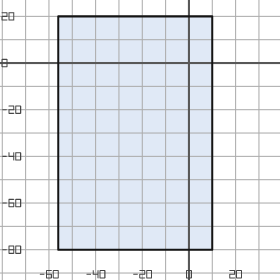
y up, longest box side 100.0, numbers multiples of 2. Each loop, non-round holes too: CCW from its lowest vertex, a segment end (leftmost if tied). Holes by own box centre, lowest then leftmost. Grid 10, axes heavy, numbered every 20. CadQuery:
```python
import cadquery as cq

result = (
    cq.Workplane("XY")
    .moveTo(-56.0, -80.0)
    .lineTo(10.0, -80.0)
    .lineTo(10.0, 20.0)
    .lineTo(-56.0, 20.0)
    .close()
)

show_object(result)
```